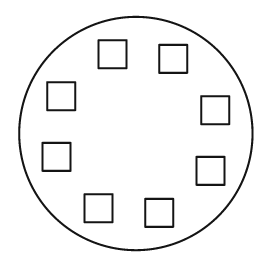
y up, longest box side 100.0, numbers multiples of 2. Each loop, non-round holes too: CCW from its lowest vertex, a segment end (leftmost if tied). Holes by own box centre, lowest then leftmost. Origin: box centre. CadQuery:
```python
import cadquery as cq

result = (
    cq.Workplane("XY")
    .moveTo(0.0, 0.0)
    .circle(50.0)
    .moveTo(4.0, -40.0)
    .lineTo(16.0, -40.0)
    .lineTo(16.0, -28.0)
    .lineTo(4.0, -28.0)
    .close()
    .moveTo(-22.0, -38.0)
    .lineTo(-10.0, -38.0)
    .lineTo(-10.0, -26.0)
    .lineTo(-22.0, -26.0)
    .close()
    .moveTo(26.0, -22.0)
    .lineTo(38.0, -22.0)
    .lineTo(38.0, -10.0)
    .lineTo(26.0, -10.0)
    .close()
    .moveTo(-40.0, -16.0)
    .lineTo(-28.0, -16.0)
    .lineTo(-28.0, -4.0)
    .lineTo(-40.0, -4.0)
    .close()
    .moveTo(28.0, 4.0)
    .lineTo(40.0, 4.0)
    .lineTo(40.0, 16.0)
    .lineTo(28.0, 16.0)
    .close()
    .moveTo(-38.0, 10.0)
    .lineTo(-26.0, 10.0)
    .lineTo(-26.0, 22.0)
    .lineTo(-38.0, 22.0)
    .close()
    .moveTo(10.0, 26.0)
    .lineTo(22.0, 26.0)
    .lineTo(22.0, 38.0)
    .lineTo(10.0, 38.0)
    .close()
    .moveTo(-16.0, 28.0)
    .lineTo(-4.0, 28.0)
    .lineTo(-4.0, 40.0)
    .lineTo(-16.0, 40.0)
    .close()
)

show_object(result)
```